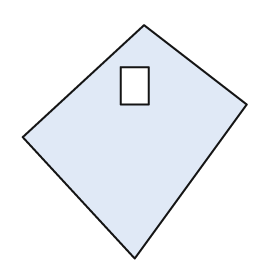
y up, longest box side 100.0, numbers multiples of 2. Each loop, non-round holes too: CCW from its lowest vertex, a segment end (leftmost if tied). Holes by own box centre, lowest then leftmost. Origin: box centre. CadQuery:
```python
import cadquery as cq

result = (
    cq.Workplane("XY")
    .moveTo(0.0, -50.0)
    .lineTo(48.0, 16.0)
    .lineTo(4.0, 50.0)
    .lineTo(-48.0, 2.0)
    .close()
    .moveTo(-6.0, 16.0)
    .lineTo(6.0, 16.0)
    .lineTo(6.0, 32.0)
    .lineTo(-6.0, 32.0)
    .close()
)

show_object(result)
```